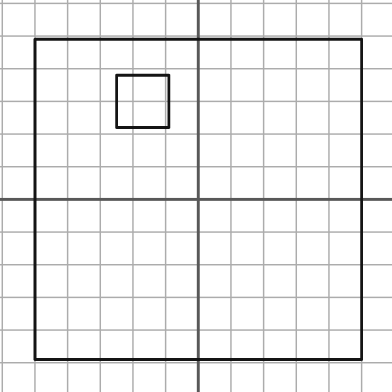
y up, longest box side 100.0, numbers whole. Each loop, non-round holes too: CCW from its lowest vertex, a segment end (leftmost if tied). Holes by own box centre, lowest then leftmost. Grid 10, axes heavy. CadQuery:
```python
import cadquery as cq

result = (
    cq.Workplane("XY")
    .moveTo(-50.0, -49.0)
    .lineTo(50.0, -49.0)
    .lineTo(50.0, 49.0)
    .lineTo(-50.0, 49.0)
    .close()
    .moveTo(-25.0, 22.0)
    .lineTo(-9.0, 22.0)
    .lineTo(-9.0, 38.0)
    .lineTo(-25.0, 38.0)
    .close()
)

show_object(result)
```